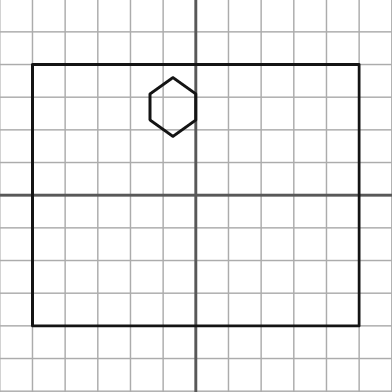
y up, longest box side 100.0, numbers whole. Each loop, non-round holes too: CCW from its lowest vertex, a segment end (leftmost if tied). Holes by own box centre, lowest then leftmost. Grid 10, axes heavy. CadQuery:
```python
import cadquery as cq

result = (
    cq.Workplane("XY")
    .moveTo(-50.0, -40.0)
    .lineTo(50.0, -40.0)
    .lineTo(50.0, 40.0)
    .lineTo(-50.0, 40.0)
    .close()
    .moveTo(-7.0, 18.0)
    .lineTo(0.0, 23.0)
    .lineTo(0.0, 31.0)
    .lineTo(-7.0, 36.0)
    .lineTo(-14.0, 31.0)
    .lineTo(-14.0, 23.0)
    .close()
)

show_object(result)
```